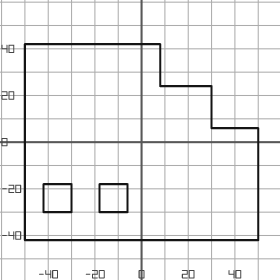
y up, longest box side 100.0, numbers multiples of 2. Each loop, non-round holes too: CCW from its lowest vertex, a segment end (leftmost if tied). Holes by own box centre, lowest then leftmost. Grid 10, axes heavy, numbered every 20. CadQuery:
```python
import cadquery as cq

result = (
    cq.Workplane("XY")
    .moveTo(-50.0, -42.0)
    .lineTo(50.0, -42.0)
    .lineTo(50.0, 6.0)
    .lineTo(30.0, 6.0)
    .lineTo(30.0, 24.0)
    .lineTo(8.0, 24.0)
    .lineTo(8.0, 42.0)
    .lineTo(-50.0, 42.0)
    .close()
    .moveTo(-42.0, -30.0)
    .lineTo(-30.0, -30.0)
    .lineTo(-30.0, -18.0)
    .lineTo(-42.0, -18.0)
    .close()
    .moveTo(-18.0, -30.0)
    .lineTo(-6.0, -30.0)
    .lineTo(-6.0, -18.0)
    .lineTo(-18.0, -18.0)
    .close()
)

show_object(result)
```